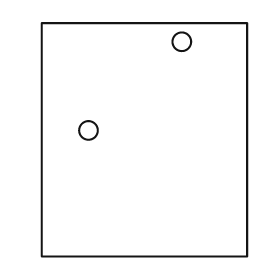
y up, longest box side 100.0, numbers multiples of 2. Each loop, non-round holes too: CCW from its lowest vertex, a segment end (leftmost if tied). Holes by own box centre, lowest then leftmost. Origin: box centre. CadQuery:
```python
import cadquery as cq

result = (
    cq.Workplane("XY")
    .moveTo(-44.0, -50.0)
    .lineTo(44.0, -50.0)
    .lineTo(44.0, 50.0)
    .lineTo(-44.0, 50.0)
    .close()
    .moveTo(-24.0, 4.0)
    .circle(4.0)
    .moveTo(16.0, 42.0)
    .circle(4.0)
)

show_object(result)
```